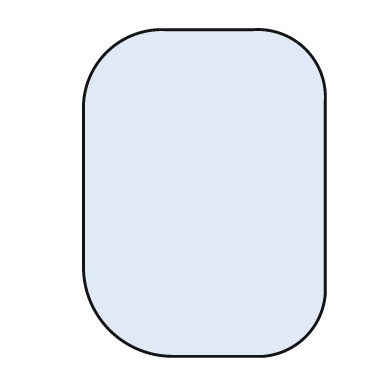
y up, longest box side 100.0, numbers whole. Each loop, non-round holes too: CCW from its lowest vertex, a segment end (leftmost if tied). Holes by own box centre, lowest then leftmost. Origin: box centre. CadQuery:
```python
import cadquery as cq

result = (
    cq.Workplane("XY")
    .moveTo(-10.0, -50.0)
    .lineTo(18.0, -50.0)
    .threePointArc((31.0, -44.0), (37.0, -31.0))
    .lineTo(37.0, 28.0)
    .threePointArc((31.0, 44.0), (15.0, 50.0))
    .lineTo(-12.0, 50.0)
    .threePointArc((-30.0, 43.0), (-37.0, 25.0))
    .lineTo(-37.0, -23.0)
    .threePointArc((-29.0, -42.0), (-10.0, -50.0))
    .close()
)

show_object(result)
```